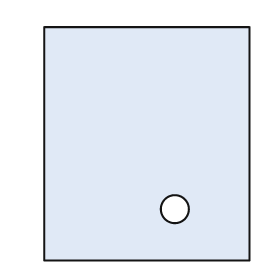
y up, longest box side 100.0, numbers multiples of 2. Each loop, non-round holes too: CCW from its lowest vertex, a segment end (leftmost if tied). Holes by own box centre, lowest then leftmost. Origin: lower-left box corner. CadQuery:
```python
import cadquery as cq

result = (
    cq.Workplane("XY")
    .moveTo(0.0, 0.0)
    .lineTo(88.0, 0.0)
    .lineTo(88.0, 100.0)
    .lineTo(0.0, 100.0)
    .close()
    .moveTo(56.0, 22.0)
    .circle(6.0)
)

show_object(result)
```